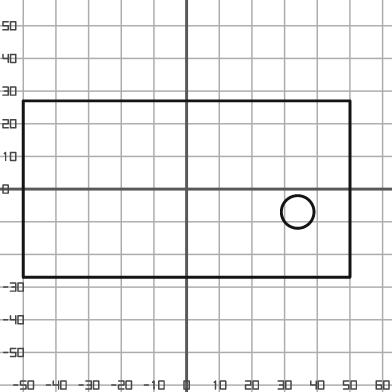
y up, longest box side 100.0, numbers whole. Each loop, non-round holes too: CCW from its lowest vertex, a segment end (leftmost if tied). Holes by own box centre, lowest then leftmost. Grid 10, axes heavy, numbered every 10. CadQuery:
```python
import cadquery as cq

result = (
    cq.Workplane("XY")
    .moveTo(-50.0, -27.0)
    .lineTo(50.0, -27.0)
    .lineTo(50.0, 27.0)
    .lineTo(-50.0, 27.0)
    .close()
    .moveTo(34.0, -7.0)
    .circle(5.0)
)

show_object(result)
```